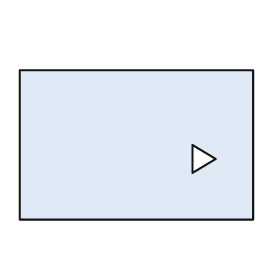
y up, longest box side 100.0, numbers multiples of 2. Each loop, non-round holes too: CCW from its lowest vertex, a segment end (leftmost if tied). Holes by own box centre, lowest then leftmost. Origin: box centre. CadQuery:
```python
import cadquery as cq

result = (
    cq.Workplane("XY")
    .moveTo(-50.0, -32.0)
    .lineTo(50.0, -32.0)
    .lineTo(50.0, 32.0)
    .lineTo(-50.0, 32.0)
    .close()
    .moveTo(24.0, -12.0)
    .lineTo(34.0, -6.0)
    .lineTo(24.0, 0.0)
    .close()
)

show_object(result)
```